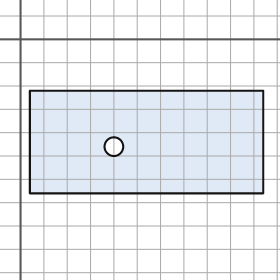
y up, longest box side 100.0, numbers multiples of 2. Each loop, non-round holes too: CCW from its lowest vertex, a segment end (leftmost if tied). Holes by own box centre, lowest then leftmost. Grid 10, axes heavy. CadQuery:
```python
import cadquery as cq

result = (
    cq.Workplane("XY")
    .moveTo(4.0, -66.0)
    .lineTo(104.0, -66.0)
    .lineTo(104.0, -22.0)
    .lineTo(4.0, -22.0)
    .close()
    .moveTo(40.0, -46.0)
    .circle(4.0)
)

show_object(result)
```